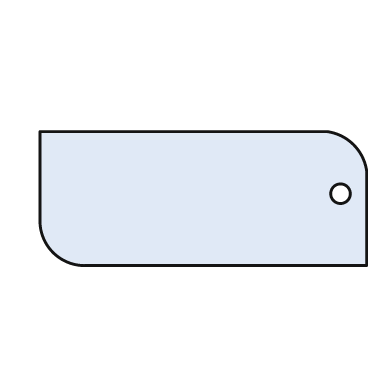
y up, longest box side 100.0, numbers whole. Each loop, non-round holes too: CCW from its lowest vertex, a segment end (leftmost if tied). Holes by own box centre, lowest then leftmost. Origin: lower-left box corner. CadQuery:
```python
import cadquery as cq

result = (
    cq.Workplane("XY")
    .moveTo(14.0, 0.0)
    .lineTo(100.0, 0.0)
    .lineTo(100.0, 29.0)
    .threePointArc((96.0, 37.0), (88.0, 41.0))
    .lineTo(0.0, 41.0)
    .lineTo(0.0, 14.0)
    .threePointArc((4.0, 4.0), (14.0, 0.0))
    .close()
    .moveTo(92.0, 22.0)
    .circle(3.0)
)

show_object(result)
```